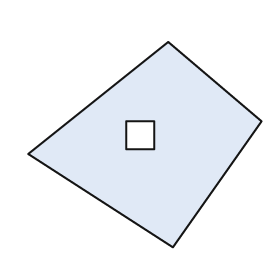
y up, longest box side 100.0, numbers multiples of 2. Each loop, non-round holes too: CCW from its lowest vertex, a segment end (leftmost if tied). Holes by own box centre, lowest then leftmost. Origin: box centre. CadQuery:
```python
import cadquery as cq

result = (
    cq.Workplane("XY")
    .moveTo(12.0, -44.0)
    .lineTo(50.0, 10.0)
    .lineTo(10.0, 44.0)
    .lineTo(-50.0, -4.0)
    .close()
    .moveTo(-8.0, -2.0)
    .lineTo(4.0, -2.0)
    .lineTo(4.0, 10.0)
    .lineTo(-8.0, 10.0)
    .close()
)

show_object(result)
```